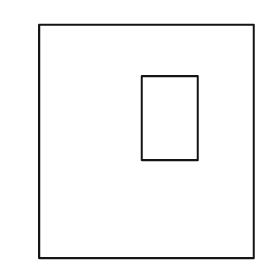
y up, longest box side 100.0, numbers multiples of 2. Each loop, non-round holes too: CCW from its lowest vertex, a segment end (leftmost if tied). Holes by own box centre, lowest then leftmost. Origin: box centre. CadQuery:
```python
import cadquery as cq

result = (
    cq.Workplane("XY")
    .moveTo(-46.0, -50.0)
    .lineTo(46.0, -50.0)
    .lineTo(46.0, 50.0)
    .lineTo(-46.0, 50.0)
    .close()
    .moveTo(-2.0, -8.0)
    .lineTo(22.0, -8.0)
    .lineTo(22.0, 28.0)
    .lineTo(-2.0, 28.0)
    .close()
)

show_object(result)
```